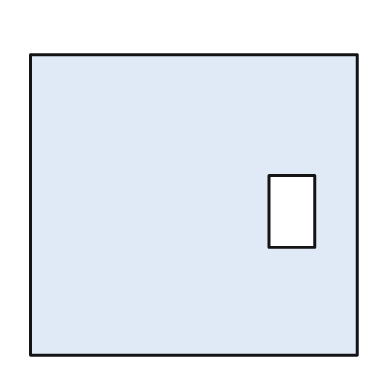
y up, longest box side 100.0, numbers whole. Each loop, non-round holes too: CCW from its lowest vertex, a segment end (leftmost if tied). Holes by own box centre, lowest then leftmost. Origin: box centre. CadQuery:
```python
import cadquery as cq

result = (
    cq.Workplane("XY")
    .moveTo(-50.0, -46.0)
    .lineTo(50.0, -46.0)
    .lineTo(50.0, 46.0)
    .lineTo(-50.0, 46.0)
    .close()
    .moveTo(23.0, -13.0)
    .lineTo(37.0, -13.0)
    .lineTo(37.0, 9.0)
    .lineTo(23.0, 9.0)
    .close()
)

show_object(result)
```